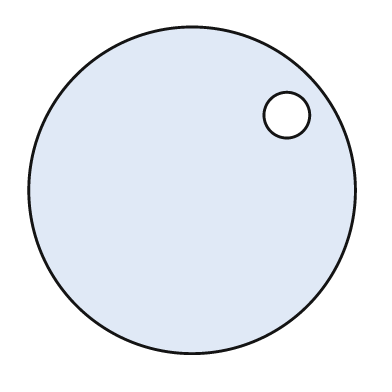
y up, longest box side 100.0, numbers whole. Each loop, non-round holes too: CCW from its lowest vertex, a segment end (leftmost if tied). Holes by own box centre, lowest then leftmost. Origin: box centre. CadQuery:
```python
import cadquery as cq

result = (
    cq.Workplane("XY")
    .moveTo(0.0, 0.0)
    .circle(50.0)
    .moveTo(29.0, 23.0)
    .circle(7.0)
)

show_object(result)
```